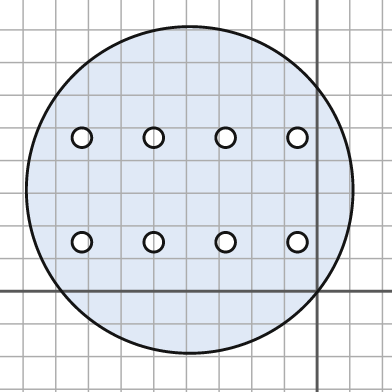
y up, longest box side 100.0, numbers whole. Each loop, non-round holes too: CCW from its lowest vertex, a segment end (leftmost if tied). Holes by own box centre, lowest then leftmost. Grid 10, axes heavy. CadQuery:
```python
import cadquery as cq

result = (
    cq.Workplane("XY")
    .moveTo(-39.0, 31.0)
    .circle(50.0)
    .moveTo(-72.0, 15.0)
    .circle(3.0)
    .moveTo(-50.0, 15.0)
    .circle(3.0)
    .moveTo(-28.0, 15.0)
    .circle(3.0)
    .moveTo(-6.0, 15.0)
    .circle(3.0)
    .moveTo(-72.0, 47.0)
    .circle(3.0)
    .moveTo(-50.0, 47.0)
    .circle(3.0)
    .moveTo(-28.0, 47.0)
    .circle(3.0)
    .moveTo(-6.0, 47.0)
    .circle(3.0)
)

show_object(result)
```